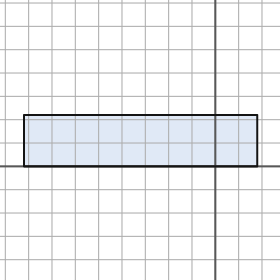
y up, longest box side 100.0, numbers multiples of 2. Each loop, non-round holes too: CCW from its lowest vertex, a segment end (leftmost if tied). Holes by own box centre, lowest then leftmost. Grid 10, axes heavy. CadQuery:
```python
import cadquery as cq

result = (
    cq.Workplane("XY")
    .moveTo(-82.0, 0.0)
    .lineTo(18.0, 0.0)
    .lineTo(18.0, 22.0)
    .lineTo(-82.0, 22.0)
    .close()
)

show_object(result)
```